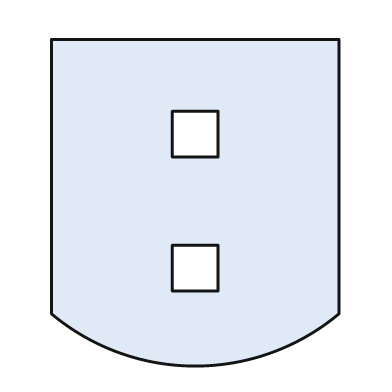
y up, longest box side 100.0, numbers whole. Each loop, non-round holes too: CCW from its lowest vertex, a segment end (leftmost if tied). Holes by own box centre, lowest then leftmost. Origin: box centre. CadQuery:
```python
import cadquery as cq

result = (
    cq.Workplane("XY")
    .moveTo(-44.0, -34.0)
    .threePointArc((0.0, -50.0), (44.0, -34.0))
    .lineTo(44.0, 50.0)
    .lineTo(-44.0, 50.0)
    .close()
    .moveTo(-7.0, -27.0)
    .lineTo(7.0, -27.0)
    .lineTo(7.0, -13.0)
    .lineTo(-7.0, -13.0)
    .close()
    .moveTo(-7.0, 14.0)
    .lineTo(7.0, 14.0)
    .lineTo(7.0, 28.0)
    .lineTo(-7.0, 28.0)
    .close()
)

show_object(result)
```